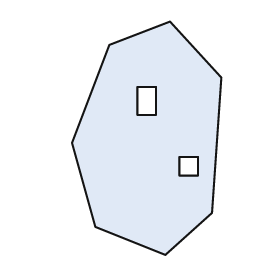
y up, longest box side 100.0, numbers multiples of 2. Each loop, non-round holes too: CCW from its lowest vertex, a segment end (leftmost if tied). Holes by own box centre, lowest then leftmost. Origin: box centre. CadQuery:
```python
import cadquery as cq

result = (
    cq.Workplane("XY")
    .moveTo(8.0, -50.0)
    .lineTo(28.0, -32.0)
    .lineTo(32.0, 26.0)
    .lineTo(10.0, 50.0)
    .lineTo(-16.0, 40.0)
    .lineTo(-32.0, -2.0)
    .lineTo(-22.0, -38.0)
    .close()
    .moveTo(14.0, -16.0)
    .lineTo(22.0, -16.0)
    .lineTo(22.0, -8.0)
    .lineTo(14.0, -8.0)
    .close()
    .moveTo(-4.0, 10.0)
    .lineTo(4.0, 10.0)
    .lineTo(4.0, 22.0)
    .lineTo(-4.0, 22.0)
    .close()
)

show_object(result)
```